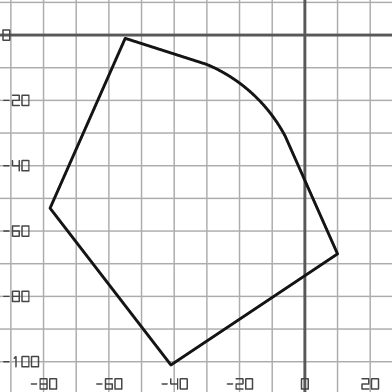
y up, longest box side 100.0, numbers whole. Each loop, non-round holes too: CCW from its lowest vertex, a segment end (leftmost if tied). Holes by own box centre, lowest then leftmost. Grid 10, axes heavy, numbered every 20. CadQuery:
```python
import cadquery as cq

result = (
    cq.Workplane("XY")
    .moveTo(-41.0, -101.0)
    .lineTo(10.0, -67.0)
    .lineTo(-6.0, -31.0)
    .threePointArc((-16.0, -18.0), (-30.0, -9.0))
    .lineTo(-55.0, -1.0)
    .lineTo(-78.0, -53.0)
    .close()
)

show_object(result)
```